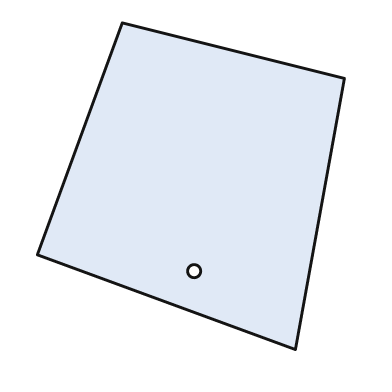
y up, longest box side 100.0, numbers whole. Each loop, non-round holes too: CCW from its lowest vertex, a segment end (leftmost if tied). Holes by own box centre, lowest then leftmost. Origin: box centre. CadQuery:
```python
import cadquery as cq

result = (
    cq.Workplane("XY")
    .moveTo(32.0, -50.0)
    .lineTo(47.0, 33.0)
    .lineTo(-21.0, 50.0)
    .lineTo(-47.0, -21.0)
    .close()
    .moveTo(1.0, -26.0)
    .circle(2.0)
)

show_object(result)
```